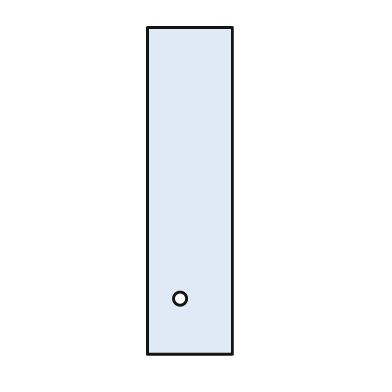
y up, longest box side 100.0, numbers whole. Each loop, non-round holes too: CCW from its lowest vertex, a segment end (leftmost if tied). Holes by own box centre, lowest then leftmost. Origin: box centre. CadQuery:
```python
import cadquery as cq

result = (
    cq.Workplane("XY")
    .moveTo(-13.0, -50.0)
    .lineTo(13.0, -50.0)
    .lineTo(13.0, 50.0)
    .lineTo(-13.0, 50.0)
    .close()
    .moveTo(-3.0, -33.0)
    .circle(2.0)
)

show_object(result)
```